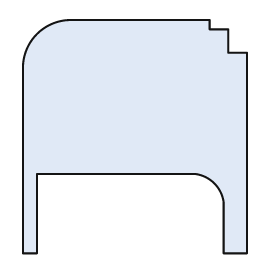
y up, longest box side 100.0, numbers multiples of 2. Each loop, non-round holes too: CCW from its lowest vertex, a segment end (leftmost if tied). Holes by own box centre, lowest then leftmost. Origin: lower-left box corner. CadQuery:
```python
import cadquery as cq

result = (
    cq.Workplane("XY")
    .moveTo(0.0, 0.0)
    .lineTo(6.0, 0.0)
    .lineTo(6.0, 34.0)
    .lineTo(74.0, 34.0)
    .threePointArc((82.0, 30.0), (86.0, 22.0))
    .lineTo(86.0, 0.0)
    .lineTo(96.0, 0.0)
    .lineTo(96.0, 86.0)
    .lineTo(88.0, 86.0)
    .lineTo(88.0, 96.0)
    .lineTo(80.0, 96.0)
    .lineTo(80.0, 100.0)
    .lineTo(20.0, 100.0)
    .threePointArc((6.0, 94.0), (0.0, 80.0))
    .close()
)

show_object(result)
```